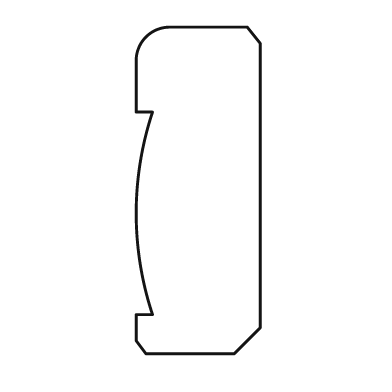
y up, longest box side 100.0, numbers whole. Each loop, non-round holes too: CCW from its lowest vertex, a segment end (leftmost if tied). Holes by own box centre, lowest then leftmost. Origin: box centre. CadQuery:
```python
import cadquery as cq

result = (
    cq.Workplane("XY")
    .moveTo(-16.0, -50.0)
    .lineTo(11.0, -50.0)
    .lineTo(19.0, -42.0)
    .lineTo(19.0, 45.0)
    .lineTo(15.0, 50.0)
    .lineTo(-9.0, 50.0)
    .threePointArc((-16.0, 47.0), (-19.0, 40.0))
    .lineTo(-19.0, 24.0)
    .lineTo(-14.0, 24.0)
    .threePointArc((-19.0, -7.0), (-14.0, -38.0))
    .lineTo(-19.0, -38.0)
    .lineTo(-19.0, -46.0)
    .close()
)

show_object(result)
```